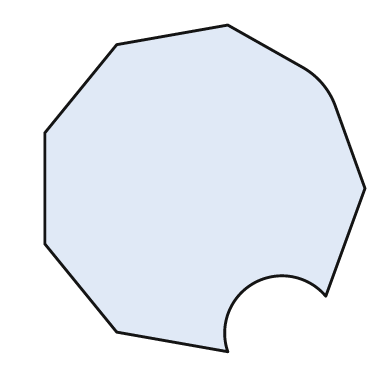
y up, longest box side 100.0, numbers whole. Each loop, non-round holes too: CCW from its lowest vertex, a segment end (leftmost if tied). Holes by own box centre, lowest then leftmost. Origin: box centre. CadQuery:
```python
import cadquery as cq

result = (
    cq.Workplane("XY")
    .moveTo(7.0, -50.0)
    .threePointArc((15.0, -29.0), (37.0, -33.0))
    .lineTo(49.0, 0.0)
    .lineTo(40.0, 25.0)
    .threePointArc((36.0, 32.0), (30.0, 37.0))
    .lineTo(7.0, 50.0)
    .lineTo(-27.0, 44.0)
    .lineTo(-49.0, 17.0)
    .lineTo(-49.0, -17.0)
    .lineTo(-27.0, -44.0)
    .close()
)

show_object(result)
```